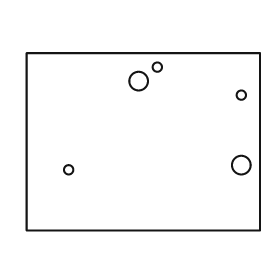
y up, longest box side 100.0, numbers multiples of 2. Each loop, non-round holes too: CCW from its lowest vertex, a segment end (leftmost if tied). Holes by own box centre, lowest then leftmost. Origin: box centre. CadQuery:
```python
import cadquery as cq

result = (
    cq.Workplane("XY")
    .moveTo(-50.0, -38.0)
    .lineTo(50.0, -38.0)
    .lineTo(50.0, 38.0)
    .lineTo(-50.0, 38.0)
    .close()
    .moveTo(-32.0, -12.0)
    .circle(2.0)
    .moveTo(42.0, -10.0)
    .circle(4.0)
    .moveTo(42.0, 20.0)
    .circle(2.0)
    .moveTo(-2.0, 26.0)
    .circle(4.0)
    .moveTo(6.0, 32.0)
    .circle(2.0)
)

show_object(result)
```